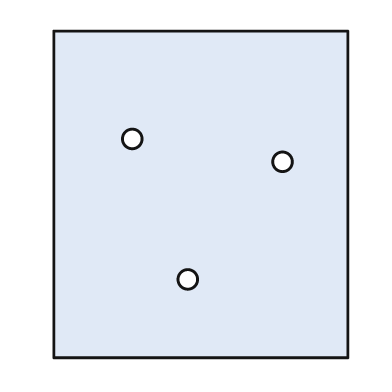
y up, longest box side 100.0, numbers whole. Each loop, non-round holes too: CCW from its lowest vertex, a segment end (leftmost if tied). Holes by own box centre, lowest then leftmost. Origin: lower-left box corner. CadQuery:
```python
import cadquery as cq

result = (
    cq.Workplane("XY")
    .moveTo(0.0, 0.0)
    .lineTo(90.0, 0.0)
    .lineTo(90.0, 100.0)
    .lineTo(0.0, 100.0)
    .close()
    .moveTo(41.0, 24.0)
    .circle(3.0)
    .moveTo(70.0, 60.0)
    .circle(3.0)
    .moveTo(24.0, 67.0)
    .circle(3.0)
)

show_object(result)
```